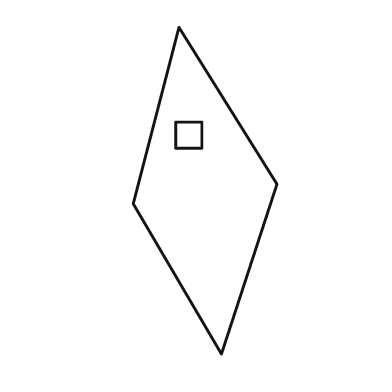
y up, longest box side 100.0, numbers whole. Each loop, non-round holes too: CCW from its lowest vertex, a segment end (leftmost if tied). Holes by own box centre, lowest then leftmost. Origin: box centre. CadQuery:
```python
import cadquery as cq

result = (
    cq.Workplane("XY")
    .moveTo(5.0, -50.0)
    .lineTo(22.0, 2.0)
    .lineTo(-8.0, 50.0)
    .lineTo(-22.0, -4.0)
    .close()
    .moveTo(-9.0, 13.0)
    .lineTo(-1.0, 13.0)
    .lineTo(-1.0, 21.0)
    .lineTo(-9.0, 21.0)
    .close()
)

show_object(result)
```